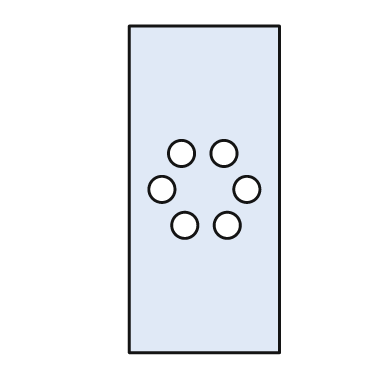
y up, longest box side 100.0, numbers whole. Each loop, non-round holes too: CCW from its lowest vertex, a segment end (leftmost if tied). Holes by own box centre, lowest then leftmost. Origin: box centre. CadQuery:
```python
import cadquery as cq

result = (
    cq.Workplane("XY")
    .moveTo(-23.0, -50.0)
    .lineTo(23.0, -50.0)
    .lineTo(23.0, 50.0)
    .lineTo(-23.0, 50.0)
    .close()
    .moveTo(-6.0, -11.0)
    .circle(4.0)
    .moveTo(7.0, -11.0)
    .circle(4.0)
    .moveTo(-13.0, 0.0)
    .circle(4.0)
    .moveTo(13.0, 0.0)
    .circle(4.0)
    .moveTo(-7.0, 11.0)
    .circle(4.0)
    .moveTo(6.0, 11.0)
    .circle(4.0)
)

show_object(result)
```